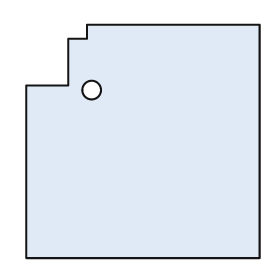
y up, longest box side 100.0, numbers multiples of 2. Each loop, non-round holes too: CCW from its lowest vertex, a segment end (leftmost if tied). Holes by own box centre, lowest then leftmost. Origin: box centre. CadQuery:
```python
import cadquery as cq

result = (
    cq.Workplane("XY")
    .moveTo(-50.0, -50.0)
    .lineTo(50.0, -50.0)
    .lineTo(50.0, 50.0)
    .lineTo(-24.0, 50.0)
    .lineTo(-24.0, 44.0)
    .lineTo(-32.0, 44.0)
    .lineTo(-32.0, 24.0)
    .lineTo(-50.0, 24.0)
    .close()
    .moveTo(-22.0, 22.0)
    .circle(4.0)
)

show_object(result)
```